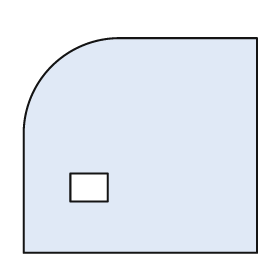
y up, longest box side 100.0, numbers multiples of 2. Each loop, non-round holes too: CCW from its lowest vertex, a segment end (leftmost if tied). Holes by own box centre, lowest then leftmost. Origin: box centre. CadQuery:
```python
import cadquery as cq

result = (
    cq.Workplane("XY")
    .moveTo(-50.0, -46.0)
    .lineTo(50.0, -46.0)
    .lineTo(50.0, 46.0)
    .lineTo(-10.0, 46.0)
    .threePointArc((-38.0, 34.0), (-50.0, 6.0))
    .close()
    .moveTo(-30.0, -24.0)
    .lineTo(-14.0, -24.0)
    .lineTo(-14.0, -12.0)
    .lineTo(-30.0, -12.0)
    .close()
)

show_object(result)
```